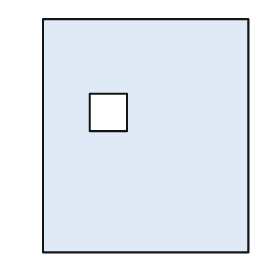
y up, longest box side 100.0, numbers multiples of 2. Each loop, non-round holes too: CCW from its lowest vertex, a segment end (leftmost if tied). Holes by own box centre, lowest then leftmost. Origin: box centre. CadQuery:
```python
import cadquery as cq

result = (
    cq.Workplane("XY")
    .moveTo(-44.0, -50.0)
    .lineTo(44.0, -50.0)
    .lineTo(44.0, 50.0)
    .lineTo(-44.0, 50.0)
    .close()
    .moveTo(-24.0, 2.0)
    .lineTo(-8.0, 2.0)
    .lineTo(-8.0, 18.0)
    .lineTo(-24.0, 18.0)
    .close()
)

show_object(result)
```